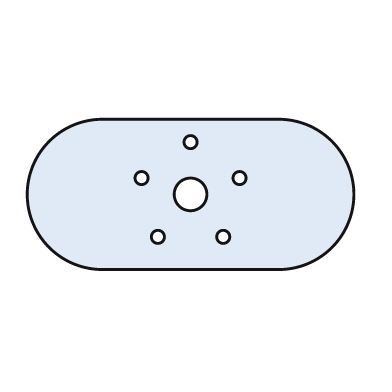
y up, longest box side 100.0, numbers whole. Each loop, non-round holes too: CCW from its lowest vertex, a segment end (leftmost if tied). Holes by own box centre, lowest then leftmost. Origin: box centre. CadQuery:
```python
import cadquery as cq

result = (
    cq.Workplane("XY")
    .moveTo(-27.0, -23.0)
    .lineTo(27.0, -23.0)
    .threePointArc((50.0, 0.0), (27.0, 23.0))
    .lineTo(-27.0, 23.0)
    .threePointArc((-50.0, 0.0), (-27.0, -23.0))
    .close()
    .moveTo(-10.0, -13.0)
    .circle(2.0)
    .moveTo(10.0, -13.0)
    .circle(2.0)
    .moveTo(0.0, 0.0)
    .circle(5.0)
    .moveTo(-15.0, 5.0)
    .circle(2.0)
    .moveTo(15.0, 5.0)
    .circle(2.0)
    .moveTo(0.0, 16.0)
    .circle(2.0)
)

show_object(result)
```